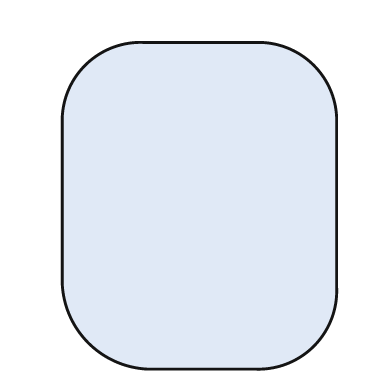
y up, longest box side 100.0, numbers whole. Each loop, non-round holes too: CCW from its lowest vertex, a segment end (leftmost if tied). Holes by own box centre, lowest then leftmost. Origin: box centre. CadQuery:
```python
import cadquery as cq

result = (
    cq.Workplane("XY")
    .moveTo(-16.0, -50.0)
    .lineTo(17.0, -50.0)
    .threePointArc((35.0, -43.0), (42.0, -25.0))
    .lineTo(42.0, 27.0)
    .threePointArc((35.0, 43.0), (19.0, 50.0))
    .lineTo(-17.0, 50.0)
    .threePointArc((-35.0, 43.0), (-42.0, 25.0))
    .lineTo(-42.0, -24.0)
    .threePointArc((-34.0, -42.0), (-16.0, -50.0))
    .close()
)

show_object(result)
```